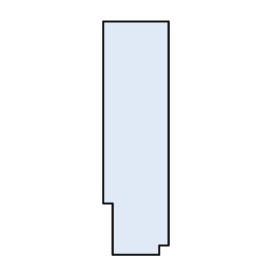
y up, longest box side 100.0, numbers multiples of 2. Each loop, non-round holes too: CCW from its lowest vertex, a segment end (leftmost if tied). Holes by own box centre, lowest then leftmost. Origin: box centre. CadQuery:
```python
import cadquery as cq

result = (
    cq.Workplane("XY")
    .moveTo(-10.0, -50.0)
    .lineTo(10.0, -50.0)
    .lineTo(10.0, -46.0)
    .lineTo(14.0, -46.0)
    .lineTo(14.0, 50.0)
    .lineTo(-14.0, 50.0)
    .lineTo(-14.0, -28.0)
    .lineTo(-10.0, -28.0)
    .close()
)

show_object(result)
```